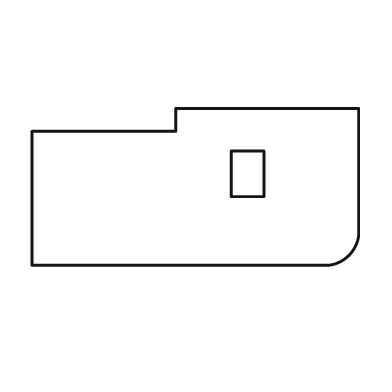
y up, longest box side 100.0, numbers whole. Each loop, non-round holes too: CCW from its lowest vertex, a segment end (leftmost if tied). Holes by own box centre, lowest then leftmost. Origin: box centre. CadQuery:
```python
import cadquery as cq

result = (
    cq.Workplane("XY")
    .moveTo(-50.0, -24.0)
    .lineTo(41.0, -24.0)
    .threePointArc((47.0, -21.0), (50.0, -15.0))
    .lineTo(50.0, 24.0)
    .lineTo(-6.0, 24.0)
    .lineTo(-6.0, 17.0)
    .lineTo(-50.0, 17.0)
    .close()
    .moveTo(11.0, -3.0)
    .lineTo(21.0, -3.0)
    .lineTo(21.0, 11.0)
    .lineTo(11.0, 11.0)
    .close()
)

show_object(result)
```